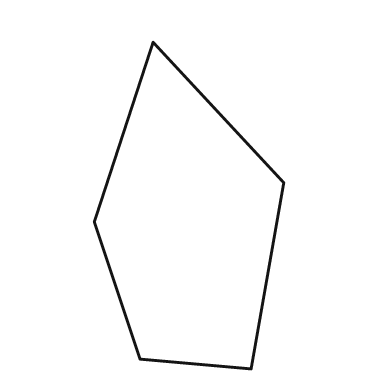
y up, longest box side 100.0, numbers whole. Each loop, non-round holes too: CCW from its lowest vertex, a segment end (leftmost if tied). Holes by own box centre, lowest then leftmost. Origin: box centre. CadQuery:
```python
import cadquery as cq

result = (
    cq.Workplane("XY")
    .moveTo(19.0, -50.0)
    .lineTo(29.0, 7.0)
    .lineTo(-11.0, 50.0)
    .lineTo(-29.0, -5.0)
    .lineTo(-15.0, -47.0)
    .close()
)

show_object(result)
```